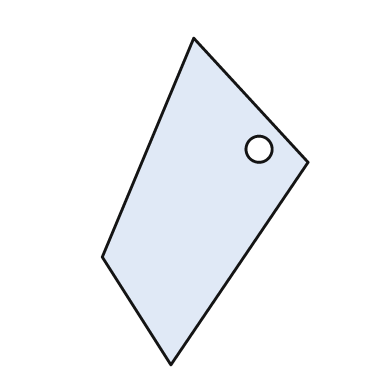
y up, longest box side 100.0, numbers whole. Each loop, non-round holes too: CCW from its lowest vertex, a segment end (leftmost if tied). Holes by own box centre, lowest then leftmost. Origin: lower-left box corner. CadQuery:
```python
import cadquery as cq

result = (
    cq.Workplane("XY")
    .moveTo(21.0, 0.0)
    .lineTo(63.0, 62.0)
    .lineTo(28.0, 100.0)
    .lineTo(0.0, 33.0)
    .close()
    .moveTo(48.0, 66.0)
    .circle(4.0)
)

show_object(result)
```